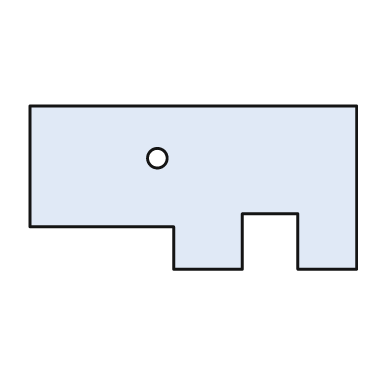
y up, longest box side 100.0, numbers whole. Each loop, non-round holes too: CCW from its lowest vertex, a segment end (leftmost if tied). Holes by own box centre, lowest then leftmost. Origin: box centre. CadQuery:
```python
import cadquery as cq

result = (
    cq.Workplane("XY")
    .moveTo(-6.0, -25.0)
    .lineTo(15.0, -25.0)
    .lineTo(15.0, -8.0)
    .lineTo(32.0, -8.0)
    .lineTo(32.0, -25.0)
    .lineTo(50.0, -25.0)
    .lineTo(50.0, 25.0)
    .lineTo(-50.0, 25.0)
    .lineTo(-50.0, -12.0)
    .lineTo(-6.0, -12.0)
    .close()
    .moveTo(-11.0, 9.0)
    .circle(3.0)
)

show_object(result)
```